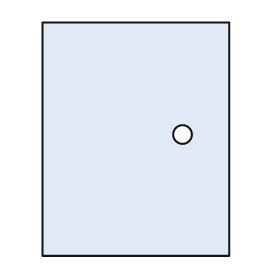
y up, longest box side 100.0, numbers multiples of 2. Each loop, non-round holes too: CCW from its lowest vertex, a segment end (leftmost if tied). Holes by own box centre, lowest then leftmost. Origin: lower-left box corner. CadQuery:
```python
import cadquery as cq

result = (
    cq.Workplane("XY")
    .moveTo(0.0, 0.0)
    .lineTo(80.0, 0.0)
    .lineTo(80.0, 100.0)
    .lineTo(0.0, 100.0)
    .close()
    .moveTo(60.0, 52.0)
    .circle(4.0)
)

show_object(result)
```